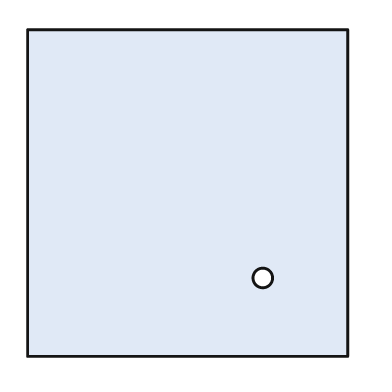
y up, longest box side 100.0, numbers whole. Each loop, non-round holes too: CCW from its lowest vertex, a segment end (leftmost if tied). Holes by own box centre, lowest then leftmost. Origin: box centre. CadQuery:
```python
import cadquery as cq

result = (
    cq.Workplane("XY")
    .moveTo(-49.0, -50.0)
    .lineTo(49.0, -50.0)
    .lineTo(49.0, 50.0)
    .lineTo(-49.0, 50.0)
    .close()
    .moveTo(23.0, -26.0)
    .circle(3.0)
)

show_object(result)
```